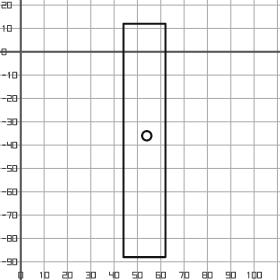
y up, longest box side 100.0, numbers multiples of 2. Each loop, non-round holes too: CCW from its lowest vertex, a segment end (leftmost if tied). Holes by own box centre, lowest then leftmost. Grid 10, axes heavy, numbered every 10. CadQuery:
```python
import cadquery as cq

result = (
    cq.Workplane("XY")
    .moveTo(44.0, -88.0)
    .lineTo(62.0, -88.0)
    .lineTo(62.0, 12.0)
    .lineTo(44.0, 12.0)
    .close()
    .moveTo(54.0, -36.0)
    .circle(2.0)
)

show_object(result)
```